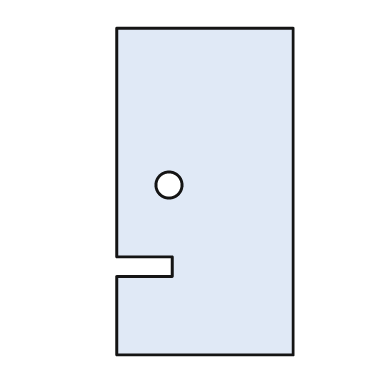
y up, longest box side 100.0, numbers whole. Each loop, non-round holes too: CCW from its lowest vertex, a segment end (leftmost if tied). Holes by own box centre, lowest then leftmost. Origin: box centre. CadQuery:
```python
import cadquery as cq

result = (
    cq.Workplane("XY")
    .moveTo(-27.0, -50.0)
    .lineTo(27.0, -50.0)
    .lineTo(27.0, 50.0)
    .lineTo(-27.0, 50.0)
    .lineTo(-27.0, -20.0)
    .lineTo(-10.0, -20.0)
    .lineTo(-10.0, -26.0)
    .lineTo(-27.0, -26.0)
    .close()
    .moveTo(-11.0, 2.0)
    .circle(4.0)
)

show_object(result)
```